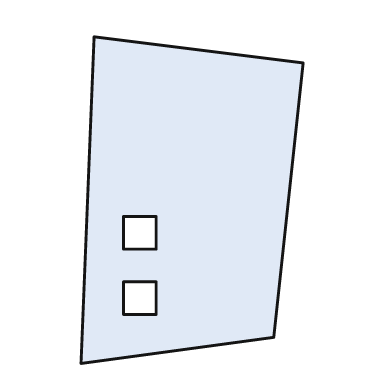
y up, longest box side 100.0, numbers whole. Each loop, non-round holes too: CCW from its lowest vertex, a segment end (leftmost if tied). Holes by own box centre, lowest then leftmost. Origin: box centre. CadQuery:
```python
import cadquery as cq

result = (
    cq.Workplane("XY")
    .moveTo(-34.0, -50.0)
    .lineTo(25.0, -42.0)
    .lineTo(34.0, 42.0)
    .lineTo(-30.0, 50.0)
    .close()
    .moveTo(-21.0, -35.0)
    .lineTo(-11.0, -35.0)
    .lineTo(-11.0, -25.0)
    .lineTo(-21.0, -25.0)
    .close()
    .moveTo(-21.0, -15.0)
    .lineTo(-11.0, -15.0)
    .lineTo(-11.0, -5.0)
    .lineTo(-21.0, -5.0)
    .close()
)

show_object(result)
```